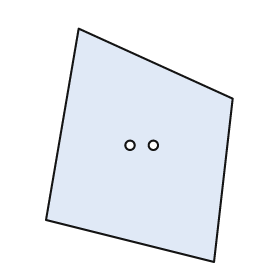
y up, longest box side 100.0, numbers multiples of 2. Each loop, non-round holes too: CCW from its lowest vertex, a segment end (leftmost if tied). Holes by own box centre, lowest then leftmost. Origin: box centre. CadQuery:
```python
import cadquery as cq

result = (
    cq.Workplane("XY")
    .moveTo(32.0, -50.0)
    .lineTo(40.0, 20.0)
    .lineTo(-26.0, 50.0)
    .lineTo(-40.0, -32.0)
    .close()
    .moveTo(-4.0, 0.0)
    .circle(2.0)
    .moveTo(6.0, 0.0)
    .circle(2.0)
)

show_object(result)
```